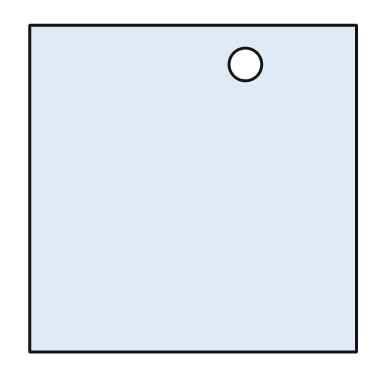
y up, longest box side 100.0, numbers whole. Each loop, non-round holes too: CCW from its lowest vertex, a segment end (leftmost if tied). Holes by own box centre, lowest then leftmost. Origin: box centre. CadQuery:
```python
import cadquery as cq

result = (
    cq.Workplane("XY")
    .moveTo(-50.0, -50.0)
    .lineTo(50.0, -50.0)
    .lineTo(50.0, 50.0)
    .lineTo(-50.0, 50.0)
    .close()
    .moveTo(16.0, 38.0)
    .circle(5.0)
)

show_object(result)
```